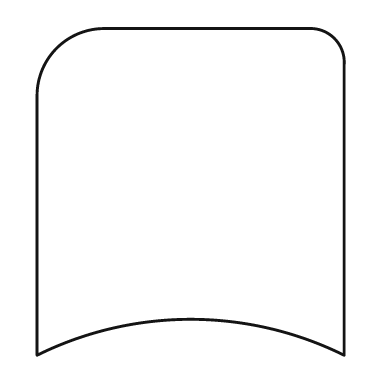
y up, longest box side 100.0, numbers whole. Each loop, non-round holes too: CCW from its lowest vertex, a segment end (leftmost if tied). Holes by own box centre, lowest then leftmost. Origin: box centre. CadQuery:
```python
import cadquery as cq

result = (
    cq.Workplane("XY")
    .moveTo(-47.0, -50.0)
    .threePointArc((0.0, -39.0), (47.0, -50.0))
    .lineTo(47.0, 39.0)
    .threePointArc((44.0, 47.0), (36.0, 50.0))
    .lineTo(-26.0, 50.0)
    .threePointArc((-41.0, 44.0), (-47.0, 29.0))
    .close()
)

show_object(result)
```